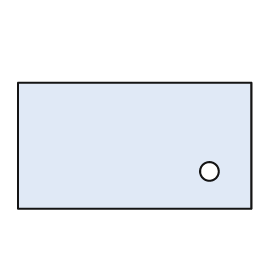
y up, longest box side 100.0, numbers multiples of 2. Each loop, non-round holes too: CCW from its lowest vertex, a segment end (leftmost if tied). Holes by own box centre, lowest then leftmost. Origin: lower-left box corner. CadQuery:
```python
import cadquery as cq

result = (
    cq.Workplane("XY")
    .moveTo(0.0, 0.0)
    .lineTo(100.0, 0.0)
    .lineTo(100.0, 54.0)
    .lineTo(0.0, 54.0)
    .close()
    .moveTo(82.0, 16.0)
    .circle(4.0)
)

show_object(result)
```